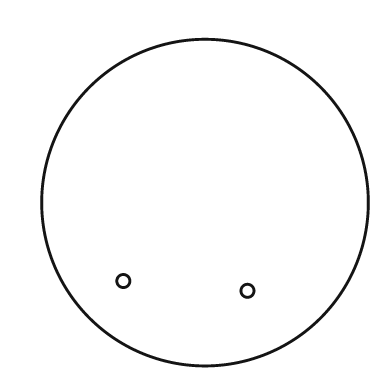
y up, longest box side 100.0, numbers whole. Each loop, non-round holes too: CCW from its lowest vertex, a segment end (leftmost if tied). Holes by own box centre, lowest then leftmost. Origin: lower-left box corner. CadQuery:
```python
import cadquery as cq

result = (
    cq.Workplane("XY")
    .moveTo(50.0, 50.0)
    .circle(50.0)
    .moveTo(63.0, 23.0)
    .circle(2.0)
    .moveTo(25.0, 26.0)
    .circle(2.0)
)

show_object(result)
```